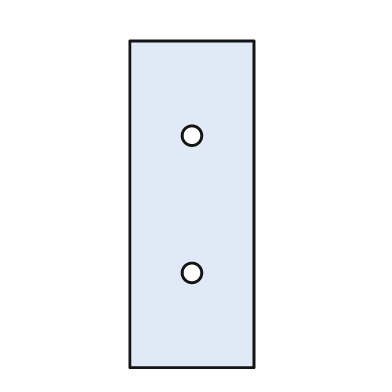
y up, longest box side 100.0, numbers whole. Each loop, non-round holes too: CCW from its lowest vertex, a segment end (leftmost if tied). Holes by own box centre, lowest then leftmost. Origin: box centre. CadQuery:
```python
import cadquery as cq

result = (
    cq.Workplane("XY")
    .moveTo(-19.0, -50.0)
    .lineTo(19.0, -50.0)
    .lineTo(19.0, 50.0)
    .lineTo(-19.0, 50.0)
    .close()
    .moveTo(0.0, -21.0)
    .circle(3.0)
    .moveTo(0.0, 21.0)
    .circle(3.0)
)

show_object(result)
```